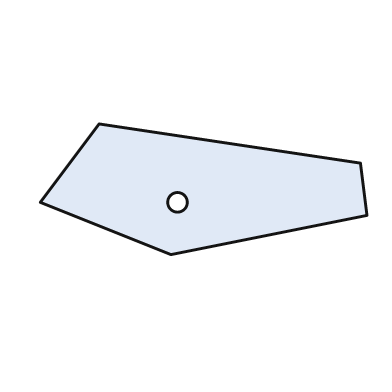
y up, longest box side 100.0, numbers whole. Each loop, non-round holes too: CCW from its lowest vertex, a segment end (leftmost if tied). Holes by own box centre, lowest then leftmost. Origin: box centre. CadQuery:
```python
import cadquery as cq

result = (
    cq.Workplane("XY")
    .moveTo(-10.0, -20.0)
    .lineTo(50.0, -8.0)
    .lineTo(48.0, 8.0)
    .lineTo(-32.0, 20.0)
    .lineTo(-50.0, -4.0)
    .close()
    .moveTo(-8.0, -4.0)
    .circle(3.0)
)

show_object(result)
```